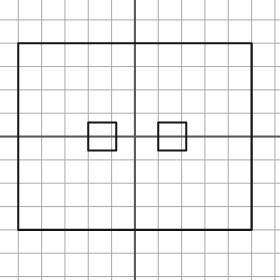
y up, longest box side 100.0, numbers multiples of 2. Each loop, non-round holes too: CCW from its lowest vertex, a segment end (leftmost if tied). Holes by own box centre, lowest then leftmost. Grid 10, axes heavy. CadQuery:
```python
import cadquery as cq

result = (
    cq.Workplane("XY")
    .moveTo(-50.0, -40.0)
    .lineTo(50.0, -40.0)
    .lineTo(50.0, 40.0)
    .lineTo(-50.0, 40.0)
    .close()
    .moveTo(-20.0, -6.0)
    .lineTo(-8.0, -6.0)
    .lineTo(-8.0, 6.0)
    .lineTo(-20.0, 6.0)
    .close()
    .moveTo(10.0, -6.0)
    .lineTo(22.0, -6.0)
    .lineTo(22.0, 6.0)
    .lineTo(10.0, 6.0)
    .close()
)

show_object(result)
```